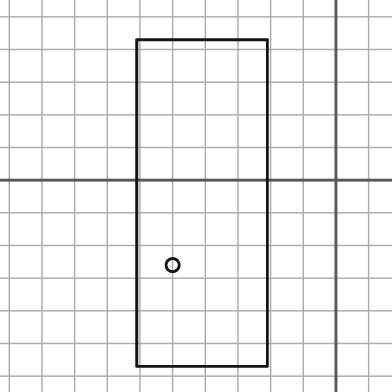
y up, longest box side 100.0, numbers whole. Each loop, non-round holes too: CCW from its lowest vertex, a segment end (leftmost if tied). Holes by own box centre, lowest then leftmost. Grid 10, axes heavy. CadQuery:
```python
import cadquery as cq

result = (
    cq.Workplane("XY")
    .moveTo(-61.0, -57.0)
    .lineTo(-21.0, -57.0)
    .lineTo(-21.0, 43.0)
    .lineTo(-61.0, 43.0)
    .close()
    .moveTo(-50.0, -26.0)
    .circle(2.0)
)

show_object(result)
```